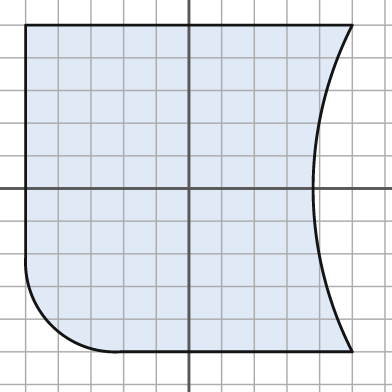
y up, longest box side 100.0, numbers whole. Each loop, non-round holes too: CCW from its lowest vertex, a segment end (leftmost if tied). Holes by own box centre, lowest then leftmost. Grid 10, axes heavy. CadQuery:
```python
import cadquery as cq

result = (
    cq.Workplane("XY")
    .moveTo(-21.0, -50.0)
    .lineTo(50.0, -50.0)
    .threePointArc((38.0, 0.0), (50.0, 50.0))
    .lineTo(-50.0, 50.0)
    .lineTo(-50.0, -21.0)
    .threePointArc((-42.0, -42.0), (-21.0, -50.0))
    .close()
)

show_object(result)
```